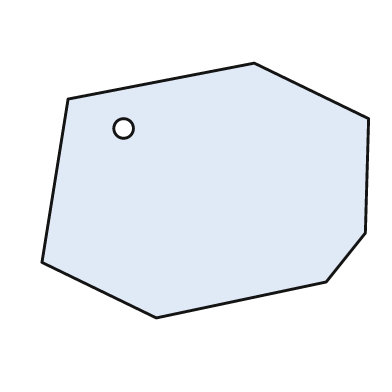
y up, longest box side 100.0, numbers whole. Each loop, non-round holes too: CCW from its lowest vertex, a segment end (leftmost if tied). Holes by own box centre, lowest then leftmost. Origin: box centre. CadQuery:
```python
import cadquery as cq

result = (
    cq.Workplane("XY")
    .moveTo(-15.0, -39.0)
    .lineTo(37.0, -28.0)
    .lineTo(49.0, -13.0)
    .lineTo(50.0, 22.0)
    .lineTo(15.0, 39.0)
    .lineTo(-42.0, 28.0)
    .lineTo(-50.0, -22.0)
    .close()
    .moveTo(-25.0, 19.0)
    .circle(3.0)
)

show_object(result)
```